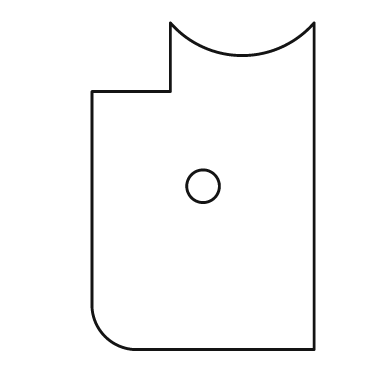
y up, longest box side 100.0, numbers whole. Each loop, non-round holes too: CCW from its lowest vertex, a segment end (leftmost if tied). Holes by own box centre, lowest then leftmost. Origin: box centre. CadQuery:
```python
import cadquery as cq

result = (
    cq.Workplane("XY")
    .moveTo(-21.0, -50.0)
    .lineTo(34.0, -50.0)
    .lineTo(34.0, 50.0)
    .threePointArc((12.0, 40.0), (-10.0, 50.0))
    .lineTo(-10.0, 29.0)
    .lineTo(-34.0, 29.0)
    .lineTo(-34.0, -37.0)
    .threePointArc((-30.0, -46.0), (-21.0, -50.0))
    .close()
    .moveTo(0.0, 0.0)
    .circle(5.0)
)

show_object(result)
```